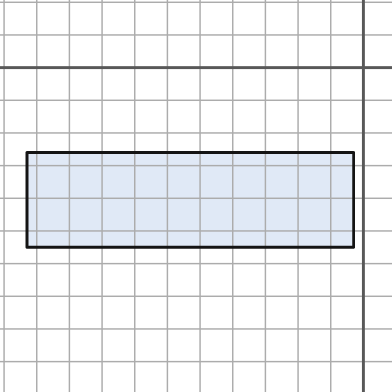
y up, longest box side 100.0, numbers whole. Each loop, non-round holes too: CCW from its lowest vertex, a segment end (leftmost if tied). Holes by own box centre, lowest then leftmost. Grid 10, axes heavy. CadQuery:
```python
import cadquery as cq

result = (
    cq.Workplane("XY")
    .moveTo(-103.0, -55.0)
    .lineTo(-3.0, -55.0)
    .lineTo(-3.0, -26.0)
    .lineTo(-103.0, -26.0)
    .close()
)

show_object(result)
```